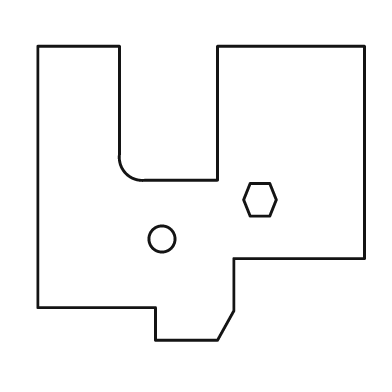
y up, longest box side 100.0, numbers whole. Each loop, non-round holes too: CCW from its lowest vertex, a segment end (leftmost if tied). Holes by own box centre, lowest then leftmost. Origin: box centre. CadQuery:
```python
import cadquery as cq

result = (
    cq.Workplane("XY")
    .moveTo(-14.0, -45.0)
    .lineTo(5.0, -45.0)
    .lineTo(10.0, -36.0)
    .lineTo(10.0, -20.0)
    .lineTo(50.0, -20.0)
    .lineTo(50.0, 45.0)
    .lineTo(5.0, 45.0)
    .lineTo(5.0, 4.0)
    .lineTo(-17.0, 4.0)
    .threePointArc((-23.0, 6.0), (-25.0, 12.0))
    .lineTo(-25.0, 45.0)
    .lineTo(-50.0, 45.0)
    .lineTo(-50.0, -35.0)
    .lineTo(-14.0, -35.0)
    .close()
    .moveTo(-12.0, -14.0)
    .circle(4.0)
    .moveTo(15.0, -7.0)
    .lineTo(21.0, -7.0)
    .lineTo(23.0, -2.0)
    .lineTo(21.0, 3.0)
    .lineTo(15.0, 3.0)
    .lineTo(13.0, -2.0)
    .close()
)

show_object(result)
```